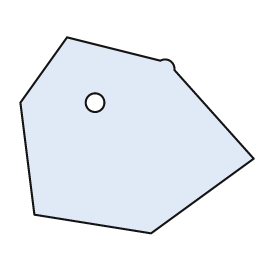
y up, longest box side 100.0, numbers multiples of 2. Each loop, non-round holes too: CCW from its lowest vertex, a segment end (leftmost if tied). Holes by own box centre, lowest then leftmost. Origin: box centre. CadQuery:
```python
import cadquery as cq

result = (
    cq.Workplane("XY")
    .moveTo(6.0, -42.0)
    .lineTo(50.0, -10.0)
    .lineTo(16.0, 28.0)
    .threePointArc((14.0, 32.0), (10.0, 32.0))
    .lineTo(-30.0, 42.0)
    .lineTo(-50.0, 14.0)
    .lineTo(-44.0, -34.0)
    .close()
    .moveTo(-18.0, 14.0)
    .circle(4.0)
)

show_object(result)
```